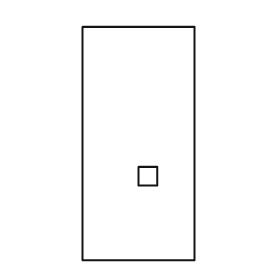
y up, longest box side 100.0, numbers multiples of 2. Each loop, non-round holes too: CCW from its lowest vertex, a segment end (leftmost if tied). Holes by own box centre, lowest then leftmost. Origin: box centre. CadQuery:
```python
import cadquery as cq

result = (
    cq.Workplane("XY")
    .moveTo(-24.0, -50.0)
    .lineTo(24.0, -50.0)
    .lineTo(24.0, 50.0)
    .lineTo(-24.0, 50.0)
    .close()
    .moveTo(0.0, -18.0)
    .lineTo(8.0, -18.0)
    .lineTo(8.0, -10.0)
    .lineTo(0.0, -10.0)
    .close()
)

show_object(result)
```